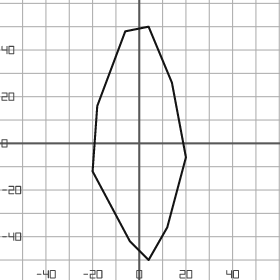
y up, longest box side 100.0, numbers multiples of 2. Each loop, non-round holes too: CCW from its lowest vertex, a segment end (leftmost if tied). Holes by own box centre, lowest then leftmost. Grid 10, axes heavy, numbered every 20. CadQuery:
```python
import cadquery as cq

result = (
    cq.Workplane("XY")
    .moveTo(4.0, -50.0)
    .lineTo(12.0, -36.0)
    .lineTo(20.0, -6.0)
    .lineTo(14.0, 26.0)
    .lineTo(4.0, 50.0)
    .lineTo(-6.0, 48.0)
    .lineTo(-18.0, 16.0)
    .lineTo(-20.0, -12.0)
    .lineTo(-4.0, -42.0)
    .close()
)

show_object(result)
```